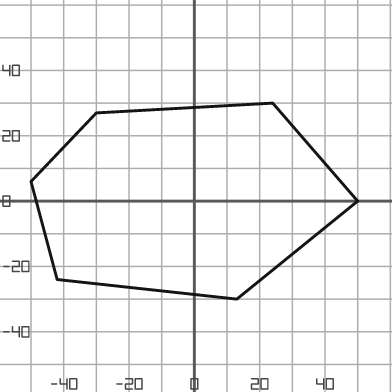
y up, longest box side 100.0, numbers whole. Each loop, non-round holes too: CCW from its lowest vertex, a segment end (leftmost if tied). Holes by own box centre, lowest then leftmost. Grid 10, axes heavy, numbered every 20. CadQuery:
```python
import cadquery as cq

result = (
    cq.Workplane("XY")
    .moveTo(13.0, -30.0)
    .lineTo(50.0, 0.0)
    .lineTo(24.0, 30.0)
    .lineTo(-30.0, 27.0)
    .lineTo(-50.0, 6.0)
    .lineTo(-42.0, -24.0)
    .close()
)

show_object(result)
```